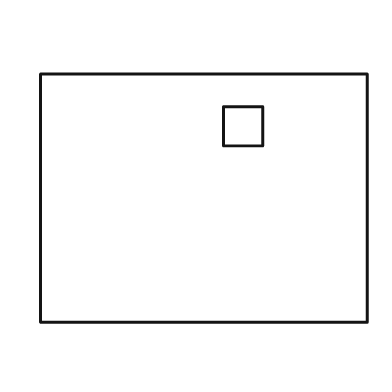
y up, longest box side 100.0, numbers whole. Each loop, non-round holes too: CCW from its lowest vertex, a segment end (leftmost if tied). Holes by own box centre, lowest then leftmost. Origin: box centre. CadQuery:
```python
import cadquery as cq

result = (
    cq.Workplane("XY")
    .moveTo(-50.0, -38.0)
    .lineTo(50.0, -38.0)
    .lineTo(50.0, 38.0)
    .lineTo(-50.0, 38.0)
    .close()
    .moveTo(6.0, 16.0)
    .lineTo(18.0, 16.0)
    .lineTo(18.0, 28.0)
    .lineTo(6.0, 28.0)
    .close()
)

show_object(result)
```